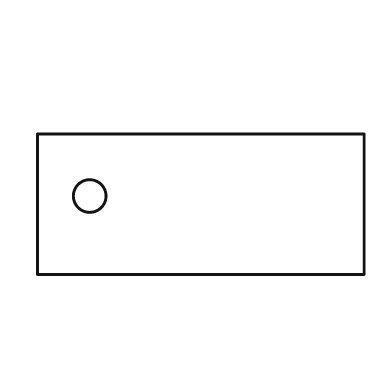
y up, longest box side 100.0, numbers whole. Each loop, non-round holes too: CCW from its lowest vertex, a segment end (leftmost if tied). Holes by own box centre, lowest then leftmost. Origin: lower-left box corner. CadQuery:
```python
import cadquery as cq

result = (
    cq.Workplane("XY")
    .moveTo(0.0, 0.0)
    .lineTo(100.0, 0.0)
    .lineTo(100.0, 43.0)
    .lineTo(0.0, 43.0)
    .close()
    .moveTo(16.0, 24.0)
    .circle(5.0)
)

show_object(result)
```